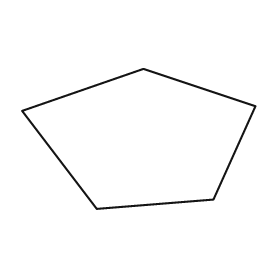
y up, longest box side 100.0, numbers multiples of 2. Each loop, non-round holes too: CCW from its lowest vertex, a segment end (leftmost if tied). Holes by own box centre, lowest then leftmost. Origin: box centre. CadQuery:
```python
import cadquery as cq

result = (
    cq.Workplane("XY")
    .moveTo(-18.0, -30.0)
    .lineTo(32.0, -26.0)
    .lineTo(50.0, 14.0)
    .lineTo(2.0, 30.0)
    .lineTo(-50.0, 12.0)
    .close()
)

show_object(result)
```